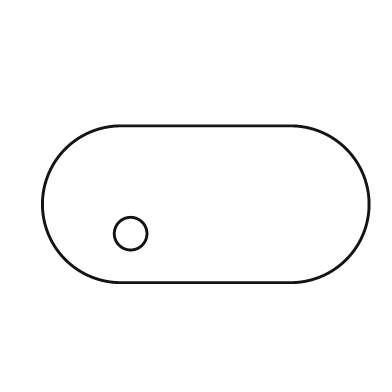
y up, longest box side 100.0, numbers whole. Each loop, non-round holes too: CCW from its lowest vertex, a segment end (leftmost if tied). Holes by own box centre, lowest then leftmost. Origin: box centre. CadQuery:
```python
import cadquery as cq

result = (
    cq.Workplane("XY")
    .moveTo(-26.0, -24.0)
    .lineTo(26.0, -24.0)
    .threePointArc((50.0, 0.0), (26.0, 24.0))
    .lineTo(-26.0, 24.0)
    .threePointArc((-50.0, 0.0), (-26.0, -24.0))
    .close()
    .moveTo(-23.0, -9.0)
    .circle(5.0)
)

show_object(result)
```